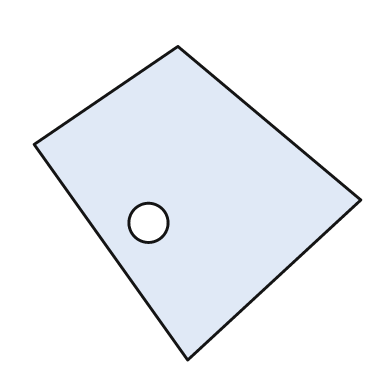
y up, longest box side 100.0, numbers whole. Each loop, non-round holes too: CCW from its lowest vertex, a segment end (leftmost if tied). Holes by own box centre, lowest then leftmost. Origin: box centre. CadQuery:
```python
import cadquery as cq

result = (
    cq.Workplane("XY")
    .moveTo(-3.0, -48.0)
    .lineTo(50.0, 1.0)
    .lineTo(-6.0, 48.0)
    .lineTo(-50.0, 18.0)
    .close()
    .moveTo(-15.0, -6.0)
    .circle(6.0)
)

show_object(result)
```